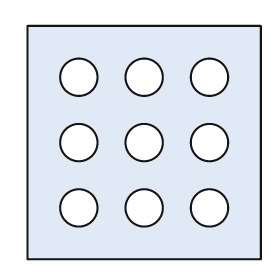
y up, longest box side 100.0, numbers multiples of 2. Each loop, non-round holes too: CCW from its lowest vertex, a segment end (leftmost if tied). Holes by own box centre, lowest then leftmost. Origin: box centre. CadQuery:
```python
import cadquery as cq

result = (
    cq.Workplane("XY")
    .moveTo(-50.0, -50.0)
    .lineTo(50.0, -50.0)
    .lineTo(50.0, 50.0)
    .lineTo(-50.0, 50.0)
    .close()
    .moveTo(-28.0, -28.0)
    .circle(8.0)
    .moveTo(0.0, -28.0)
    .circle(8.0)
    .moveTo(28.0, -28.0)
    .circle(8.0)
    .moveTo(-28.0, 0.0)
    .circle(8.0)
    .moveTo(0.0, 0.0)
    .circle(8.0)
    .moveTo(28.0, 0.0)
    .circle(8.0)
    .moveTo(-28.0, 28.0)
    .circle(8.0)
    .moveTo(0.0, 28.0)
    .circle(8.0)
    .moveTo(28.0, 28.0)
    .circle(8.0)
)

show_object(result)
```